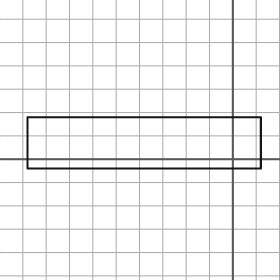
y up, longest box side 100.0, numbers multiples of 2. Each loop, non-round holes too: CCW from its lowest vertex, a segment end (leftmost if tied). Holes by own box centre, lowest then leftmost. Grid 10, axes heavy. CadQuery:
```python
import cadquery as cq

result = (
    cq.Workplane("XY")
    .moveTo(-88.0, -4.0)
    .lineTo(12.0, -4.0)
    .lineTo(12.0, 18.0)
    .lineTo(-88.0, 18.0)
    .close()
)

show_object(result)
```